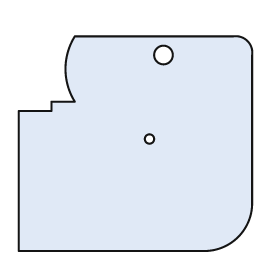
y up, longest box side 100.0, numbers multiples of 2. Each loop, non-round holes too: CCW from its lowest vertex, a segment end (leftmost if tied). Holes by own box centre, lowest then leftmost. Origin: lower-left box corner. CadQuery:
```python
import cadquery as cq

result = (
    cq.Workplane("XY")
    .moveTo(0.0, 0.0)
    .lineTo(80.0, 0.0)
    .threePointArc((94.0, 6.0), (100.0, 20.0))
    .lineTo(100.0, 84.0)
    .threePointArc((98.0, 90.0), (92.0, 92.0))
    .lineTo(24.0, 92.0)
    .threePointArc((20.0, 78.0), (24.0, 64.0))
    .lineTo(14.0, 64.0)
    .lineTo(14.0, 60.0)
    .lineTo(0.0, 60.0)
    .close()
    .moveTo(56.0, 48.0)
    .circle(2.0)
    .moveTo(62.0, 84.0)
    .circle(4.0)
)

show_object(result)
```